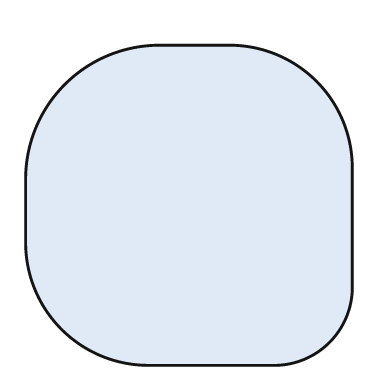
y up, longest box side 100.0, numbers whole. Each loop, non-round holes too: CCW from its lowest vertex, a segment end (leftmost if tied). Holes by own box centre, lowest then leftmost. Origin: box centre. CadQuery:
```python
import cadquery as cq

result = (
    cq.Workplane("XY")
    .moveTo(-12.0, -49.0)
    .lineTo(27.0, -49.0)
    .threePointArc((43.0, -42.0), (50.0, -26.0))
    .lineTo(50.0, 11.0)
    .threePointArc((39.0, 38.0), (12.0, 49.0))
    .lineTo(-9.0, 49.0)
    .threePointArc((-38.0, 37.0), (-50.0, 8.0))
    .lineTo(-50.0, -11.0)
    .threePointArc((-39.0, -38.0), (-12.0, -49.0))
    .close()
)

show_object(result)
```